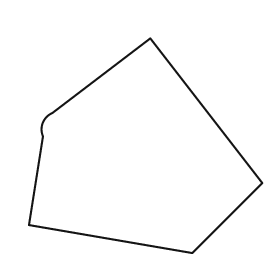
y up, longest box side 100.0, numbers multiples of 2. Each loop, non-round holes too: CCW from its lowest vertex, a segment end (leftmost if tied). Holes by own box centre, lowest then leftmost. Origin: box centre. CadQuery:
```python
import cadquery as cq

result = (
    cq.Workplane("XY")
    .moveTo(20.0, -46.0)
    .lineTo(50.0, -16.0)
    .lineTo(2.0, 46.0)
    .lineTo(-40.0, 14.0)
    .threePointArc((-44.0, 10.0), (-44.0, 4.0))
    .lineTo(-50.0, -34.0)
    .close()
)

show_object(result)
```